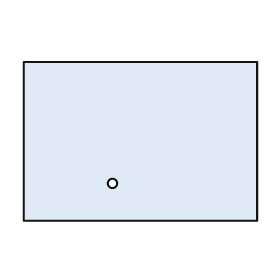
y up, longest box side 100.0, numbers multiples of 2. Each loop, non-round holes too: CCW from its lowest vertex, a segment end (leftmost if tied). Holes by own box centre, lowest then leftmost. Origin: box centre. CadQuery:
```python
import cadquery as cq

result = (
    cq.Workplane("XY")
    .moveTo(-50.0, -34.0)
    .lineTo(50.0, -34.0)
    .lineTo(50.0, 34.0)
    .lineTo(-50.0, 34.0)
    .close()
    .moveTo(-12.0, -18.0)
    .circle(2.0)
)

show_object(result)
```